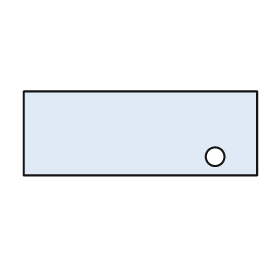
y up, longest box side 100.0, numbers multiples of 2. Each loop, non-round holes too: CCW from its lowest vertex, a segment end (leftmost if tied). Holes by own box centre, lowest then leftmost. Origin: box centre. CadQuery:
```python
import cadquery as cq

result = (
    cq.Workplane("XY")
    .moveTo(-50.0, -18.0)
    .lineTo(50.0, -18.0)
    .lineTo(50.0, 18.0)
    .lineTo(-50.0, 18.0)
    .close()
    .moveTo(32.0, -10.0)
    .circle(4.0)
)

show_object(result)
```